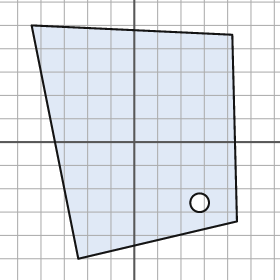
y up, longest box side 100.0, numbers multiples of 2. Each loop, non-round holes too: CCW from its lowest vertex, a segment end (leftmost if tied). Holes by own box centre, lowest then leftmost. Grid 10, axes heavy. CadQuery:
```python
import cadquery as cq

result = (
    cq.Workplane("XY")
    .moveTo(-24.0, -50.0)
    .lineTo(44.0, -34.0)
    .lineTo(42.0, 46.0)
    .lineTo(-44.0, 50.0)
    .close()
    .moveTo(28.0, -26.0)
    .circle(4.0)
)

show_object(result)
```